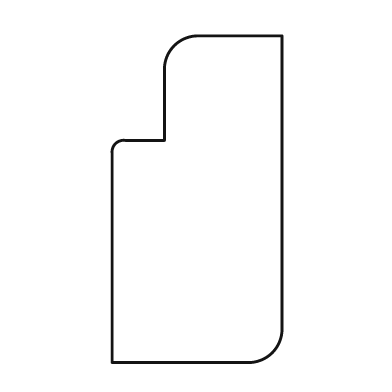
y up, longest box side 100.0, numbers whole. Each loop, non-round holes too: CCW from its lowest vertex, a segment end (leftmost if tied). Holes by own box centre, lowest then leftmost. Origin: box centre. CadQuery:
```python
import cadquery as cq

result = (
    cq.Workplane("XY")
    .moveTo(-26.0, -50.0)
    .lineTo(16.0, -50.0)
    .threePointArc((23.0, -47.0), (26.0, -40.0))
    .lineTo(26.0, 50.0)
    .lineTo(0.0, 50.0)
    .threePointArc((-7.0, 47.0), (-10.0, 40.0))
    .lineTo(-10.0, 18.0)
    .lineTo(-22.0, 18.0)
    .threePointArc((-25.0, 17.0), (-26.0, 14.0))
    .close()
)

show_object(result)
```